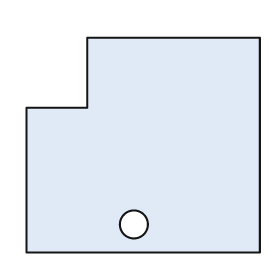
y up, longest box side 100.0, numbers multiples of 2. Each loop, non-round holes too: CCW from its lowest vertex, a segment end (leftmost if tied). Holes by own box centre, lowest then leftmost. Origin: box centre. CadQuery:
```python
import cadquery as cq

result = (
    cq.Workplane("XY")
    .moveTo(-50.0, -46.0)
    .lineTo(50.0, -46.0)
    .lineTo(50.0, 46.0)
    .lineTo(-24.0, 46.0)
    .lineTo(-24.0, 16.0)
    .lineTo(-50.0, 16.0)
    .close()
    .moveTo(-4.0, -34.0)
    .circle(6.0)
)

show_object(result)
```